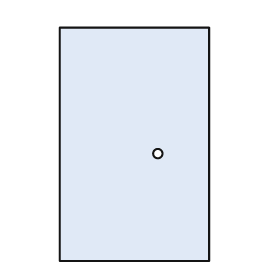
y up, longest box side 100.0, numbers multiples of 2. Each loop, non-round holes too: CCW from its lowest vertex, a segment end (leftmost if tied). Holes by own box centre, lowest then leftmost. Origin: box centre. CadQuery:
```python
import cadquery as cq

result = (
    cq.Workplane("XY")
    .moveTo(-32.0, -50.0)
    .lineTo(32.0, -50.0)
    .lineTo(32.0, 50.0)
    .lineTo(-32.0, 50.0)
    .close()
    .moveTo(10.0, -4.0)
    .circle(2.0)
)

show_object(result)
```